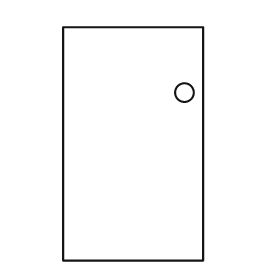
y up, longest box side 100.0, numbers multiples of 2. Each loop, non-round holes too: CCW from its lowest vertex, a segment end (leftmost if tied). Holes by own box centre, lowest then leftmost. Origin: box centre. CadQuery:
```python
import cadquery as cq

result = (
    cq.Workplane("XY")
    .moveTo(-30.0, -50.0)
    .lineTo(30.0, -50.0)
    .lineTo(30.0, 50.0)
    .lineTo(-30.0, 50.0)
    .close()
    .moveTo(22.0, 22.0)
    .circle(4.0)
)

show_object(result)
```